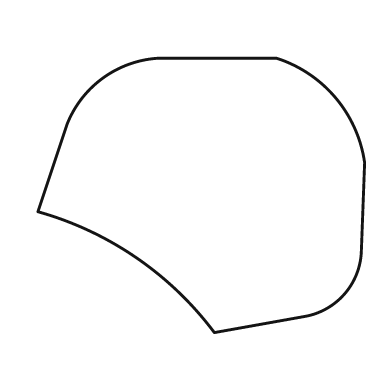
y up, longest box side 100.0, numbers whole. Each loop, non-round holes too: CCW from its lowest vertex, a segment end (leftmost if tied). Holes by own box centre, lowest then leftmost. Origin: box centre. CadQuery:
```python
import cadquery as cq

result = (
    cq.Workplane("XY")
    .moveTo(4.0, -42.0)
    .lineTo(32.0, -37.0)
    .threePointArc((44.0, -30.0), (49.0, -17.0))
    .lineTo(50.0, 10.0)
    .threePointArc((41.0, 30.0), (23.0, 42.0))
    .lineTo(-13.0, 42.0)
    .threePointArc((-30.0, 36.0), (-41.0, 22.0))
    .lineTo(-50.0, -5.0)
    .threePointArc((-20.0, -19.0), (4.0, -42.0))
    .close()
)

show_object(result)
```